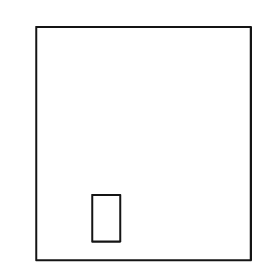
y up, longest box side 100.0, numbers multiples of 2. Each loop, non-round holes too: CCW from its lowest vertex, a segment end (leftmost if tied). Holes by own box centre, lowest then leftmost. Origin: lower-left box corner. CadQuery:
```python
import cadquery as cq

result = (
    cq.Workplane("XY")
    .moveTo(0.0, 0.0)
    .lineTo(92.0, 0.0)
    .lineTo(92.0, 100.0)
    .lineTo(0.0, 100.0)
    .close()
    .moveTo(24.0, 8.0)
    .lineTo(36.0, 8.0)
    .lineTo(36.0, 28.0)
    .lineTo(24.0, 28.0)
    .close()
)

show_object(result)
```